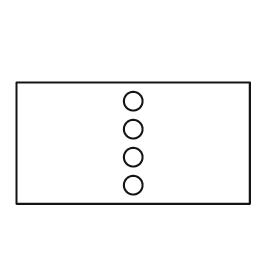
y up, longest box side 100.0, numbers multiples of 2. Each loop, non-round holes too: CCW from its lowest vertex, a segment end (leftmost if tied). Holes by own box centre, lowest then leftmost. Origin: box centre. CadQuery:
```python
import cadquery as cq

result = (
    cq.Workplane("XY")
    .moveTo(-50.0, -26.0)
    .lineTo(50.0, -26.0)
    .lineTo(50.0, 26.0)
    .lineTo(-50.0, 26.0)
    .close()
    .moveTo(0.0, -18.0)
    .circle(4.0)
    .moveTo(0.0, -6.0)
    .circle(4.0)
    .moveTo(0.0, 6.0)
    .circle(4.0)
    .moveTo(0.0, 18.0)
    .circle(4.0)
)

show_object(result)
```